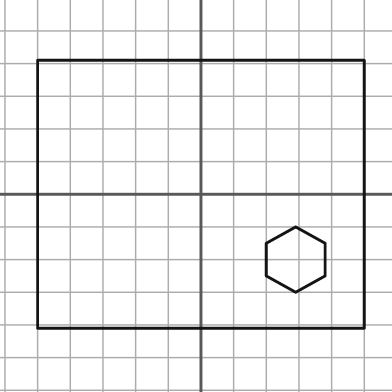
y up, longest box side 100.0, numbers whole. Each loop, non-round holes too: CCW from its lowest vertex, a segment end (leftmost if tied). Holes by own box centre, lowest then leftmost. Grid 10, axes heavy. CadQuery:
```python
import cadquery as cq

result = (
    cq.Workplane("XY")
    .moveTo(-50.0, -41.0)
    .lineTo(50.0, -41.0)
    .lineTo(50.0, 41.0)
    .lineTo(-50.0, 41.0)
    .close()
    .moveTo(29.0, -30.0)
    .lineTo(38.0, -25.0)
    .lineTo(38.0, -15.0)
    .lineTo(29.0, -10.0)
    .lineTo(20.0, -15.0)
    .lineTo(20.0, -25.0)
    .close()
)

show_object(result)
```